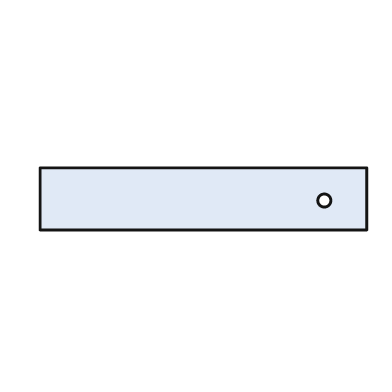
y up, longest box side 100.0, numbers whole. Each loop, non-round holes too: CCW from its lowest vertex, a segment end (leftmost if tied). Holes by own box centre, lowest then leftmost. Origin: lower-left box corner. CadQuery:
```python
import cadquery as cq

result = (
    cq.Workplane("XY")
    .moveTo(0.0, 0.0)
    .lineTo(100.0, 0.0)
    .lineTo(100.0, 19.0)
    .lineTo(0.0, 19.0)
    .close()
    .moveTo(87.0, 9.0)
    .circle(2.0)
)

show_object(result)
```